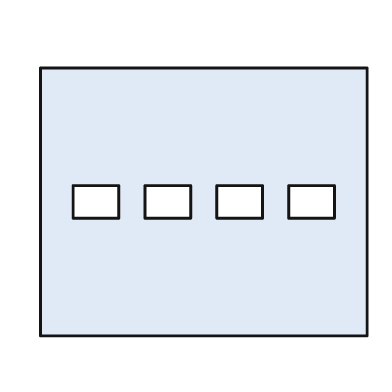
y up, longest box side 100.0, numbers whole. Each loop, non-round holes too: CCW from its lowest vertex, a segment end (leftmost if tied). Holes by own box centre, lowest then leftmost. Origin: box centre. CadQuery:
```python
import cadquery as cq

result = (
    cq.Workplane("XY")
    .moveTo(-50.0, -41.0)
    .lineTo(50.0, -41.0)
    .lineTo(50.0, 41.0)
    .lineTo(-50.0, 41.0)
    .close()
    .moveTo(-40.0, -5.0)
    .lineTo(-26.0, -5.0)
    .lineTo(-26.0, 5.0)
    .lineTo(-40.0, 5.0)
    .close()
    .moveTo(-18.0, -5.0)
    .lineTo(-4.0, -5.0)
    .lineTo(-4.0, 5.0)
    .lineTo(-18.0, 5.0)
    .close()
    .moveTo(4.0, -5.0)
    .lineTo(18.0, -5.0)
    .lineTo(18.0, 5.0)
    .lineTo(4.0, 5.0)
    .close()
    .moveTo(26.0, -5.0)
    .lineTo(40.0, -5.0)
    .lineTo(40.0, 5.0)
    .lineTo(26.0, 5.0)
    .close()
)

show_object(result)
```